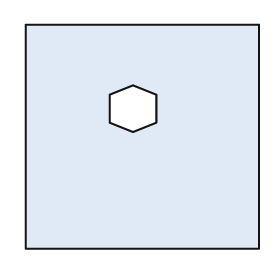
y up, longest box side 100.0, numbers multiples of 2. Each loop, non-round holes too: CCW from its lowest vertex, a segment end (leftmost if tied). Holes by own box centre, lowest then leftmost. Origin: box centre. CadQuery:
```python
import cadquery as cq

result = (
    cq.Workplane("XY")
    .moveTo(-50.0, -48.0)
    .lineTo(50.0, -48.0)
    .lineTo(50.0, 48.0)
    .lineTo(-50.0, 48.0)
    .close()
    .moveTo(-4.0, 2.0)
    .lineTo(6.0, 6.0)
    .lineTo(6.0, 18.0)
    .lineTo(-4.0, 22.0)
    .lineTo(-14.0, 18.0)
    .lineTo(-14.0, 6.0)
    .close()
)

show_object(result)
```